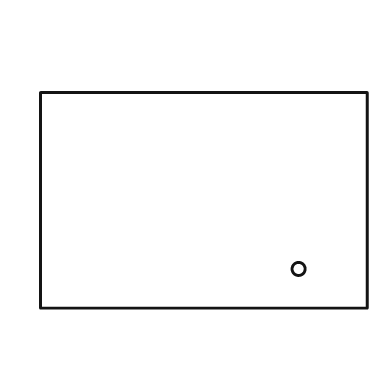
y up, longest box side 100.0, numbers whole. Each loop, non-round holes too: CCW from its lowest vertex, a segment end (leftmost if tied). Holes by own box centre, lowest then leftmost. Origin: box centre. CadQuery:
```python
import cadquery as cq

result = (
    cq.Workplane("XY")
    .moveTo(-50.0, -33.0)
    .lineTo(50.0, -33.0)
    .lineTo(50.0, 33.0)
    .lineTo(-50.0, 33.0)
    .close()
    .moveTo(29.0, -21.0)
    .circle(2.0)
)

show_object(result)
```